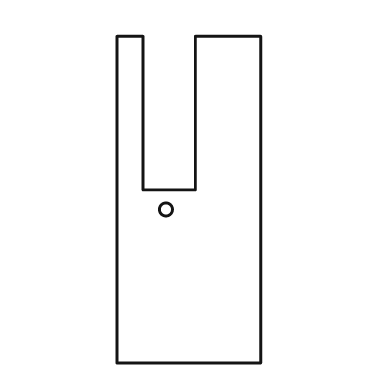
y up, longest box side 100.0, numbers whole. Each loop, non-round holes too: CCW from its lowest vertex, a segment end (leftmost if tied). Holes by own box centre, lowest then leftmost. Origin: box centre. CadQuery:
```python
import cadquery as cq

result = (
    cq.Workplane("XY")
    .moveTo(-22.0, -50.0)
    .lineTo(22.0, -50.0)
    .lineTo(22.0, 50.0)
    .lineTo(2.0, 50.0)
    .lineTo(2.0, 3.0)
    .lineTo(-14.0, 3.0)
    .lineTo(-14.0, 50.0)
    .lineTo(-22.0, 50.0)
    .close()
    .moveTo(-7.0, -3.0)
    .circle(2.0)
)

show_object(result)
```